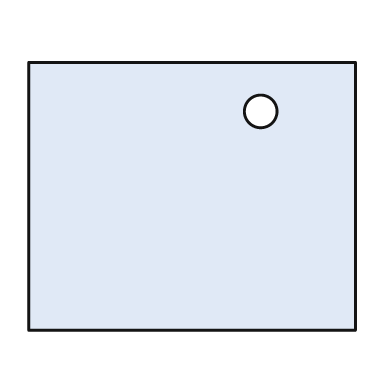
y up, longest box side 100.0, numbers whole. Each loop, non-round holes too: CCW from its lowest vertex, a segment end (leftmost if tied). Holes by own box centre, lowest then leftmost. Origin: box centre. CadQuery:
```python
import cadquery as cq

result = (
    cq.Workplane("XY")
    .moveTo(-50.0, -41.0)
    .lineTo(50.0, -41.0)
    .lineTo(50.0, 41.0)
    .lineTo(-50.0, 41.0)
    .close()
    .moveTo(21.0, 26.0)
    .circle(5.0)
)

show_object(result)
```